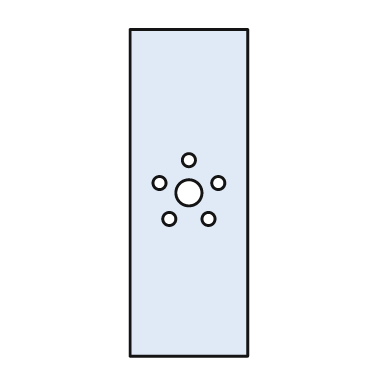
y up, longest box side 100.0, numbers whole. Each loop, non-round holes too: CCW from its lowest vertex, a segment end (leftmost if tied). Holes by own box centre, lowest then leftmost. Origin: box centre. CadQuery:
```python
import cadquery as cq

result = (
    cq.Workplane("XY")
    .moveTo(-18.0, -50.0)
    .lineTo(18.0, -50.0)
    .lineTo(18.0, 50.0)
    .lineTo(-18.0, 50.0)
    .close()
    .moveTo(-6.0, -8.0)
    .circle(2.0)
    .moveTo(6.0, -8.0)
    .circle(2.0)
    .moveTo(0.0, 0.0)
    .circle(4.0)
    .moveTo(-9.0, 3.0)
    .circle(2.0)
    .moveTo(9.0, 3.0)
    .circle(2.0)
    .moveTo(0.0, 10.0)
    .circle(2.0)
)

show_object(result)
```